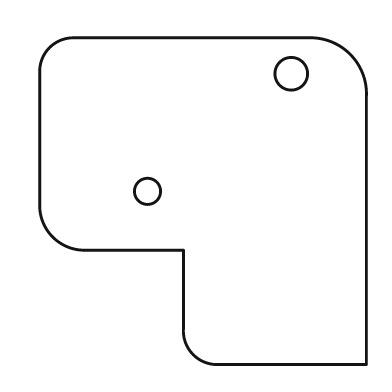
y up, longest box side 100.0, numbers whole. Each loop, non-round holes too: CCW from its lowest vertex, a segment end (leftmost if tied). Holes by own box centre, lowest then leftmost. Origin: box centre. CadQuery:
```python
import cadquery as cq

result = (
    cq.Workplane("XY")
    .moveTo(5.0, -50.0)
    .lineTo(50.0, -50.0)
    .lineTo(50.0, 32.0)
    .threePointArc((45.0, 45.0), (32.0, 50.0))
    .lineTo(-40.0, 50.0)
    .threePointArc((-47.0, 47.0), (-50.0, 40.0))
    .lineTo(-50.0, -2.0)
    .threePointArc((-46.0, -11.0), (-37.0, -15.0))
    .lineTo(-6.0, -15.0)
    .lineTo(-6.0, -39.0)
    .threePointArc((-3.0, -47.0), (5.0, -50.0))
    .close()
    .moveTo(-17.0, 3.0)
    .circle(4.0)
    .moveTo(27.0, 39.0)
    .circle(5.0)
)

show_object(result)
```